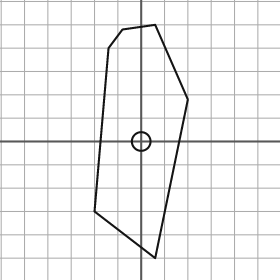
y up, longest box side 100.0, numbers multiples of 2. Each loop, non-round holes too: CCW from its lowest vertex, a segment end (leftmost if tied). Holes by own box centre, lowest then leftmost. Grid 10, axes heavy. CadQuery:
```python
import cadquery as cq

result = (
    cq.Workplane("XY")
    .moveTo(6.0, -50.0)
    .lineTo(20.0, 18.0)
    .lineTo(6.0, 50.0)
    .lineTo(-8.0, 48.0)
    .lineTo(-14.0, 40.0)
    .lineTo(-20.0, -30.0)
    .close()
    .moveTo(0.0, 0.0)
    .circle(4.0)
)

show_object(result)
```